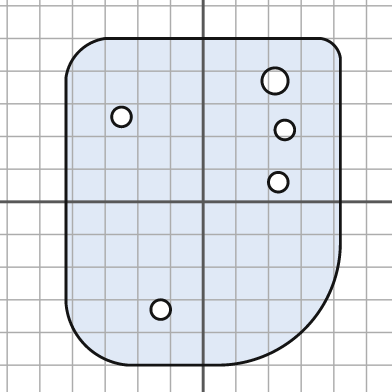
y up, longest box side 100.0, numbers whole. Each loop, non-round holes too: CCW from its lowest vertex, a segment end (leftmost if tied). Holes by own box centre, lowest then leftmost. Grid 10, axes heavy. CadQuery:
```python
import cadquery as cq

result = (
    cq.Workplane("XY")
    .moveTo(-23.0, -50.0)
    .lineTo(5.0, -50.0)
    .threePointArc((31.0, -39.0), (42.0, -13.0))
    .lineTo(42.0, 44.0)
    .threePointArc((40.0, 48.0), (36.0, 50.0))
    .lineTo(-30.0, 50.0)
    .threePointArc((-38.0, 46.0), (-42.0, 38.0))
    .lineTo(-42.0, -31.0)
    .threePointArc((-36.0, -44.0), (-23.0, -50.0))
    .close()
    .moveTo(-13.0, -33.0)
    .circle(3.0)
    .moveTo(23.0, 6.0)
    .circle(3.0)
    .moveTo(25.0, 22.0)
    .circle(3.0)
    .moveTo(-25.0, 26.0)
    .circle(3.0)
    .moveTo(22.0, 37.0)
    .circle(4.0)
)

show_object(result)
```